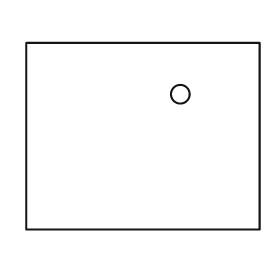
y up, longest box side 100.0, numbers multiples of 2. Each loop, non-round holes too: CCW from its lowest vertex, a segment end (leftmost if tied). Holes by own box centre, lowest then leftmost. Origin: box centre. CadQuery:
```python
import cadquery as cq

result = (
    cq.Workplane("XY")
    .moveTo(-50.0, -40.0)
    .lineTo(50.0, -40.0)
    .lineTo(50.0, 40.0)
    .lineTo(-50.0, 40.0)
    .close()
    .moveTo(16.0, 18.0)
    .circle(4.0)
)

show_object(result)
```